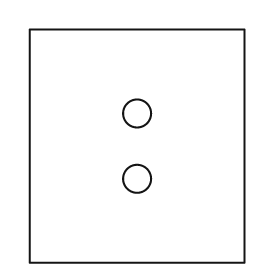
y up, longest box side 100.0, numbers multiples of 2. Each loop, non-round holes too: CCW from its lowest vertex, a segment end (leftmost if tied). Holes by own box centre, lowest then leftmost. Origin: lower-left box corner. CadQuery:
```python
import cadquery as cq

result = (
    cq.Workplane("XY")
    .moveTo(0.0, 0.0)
    .lineTo(92.0, 0.0)
    .lineTo(92.0, 100.0)
    .lineTo(0.0, 100.0)
    .close()
    .moveTo(46.0, 36.0)
    .circle(6.0)
    .moveTo(46.0, 64.0)
    .circle(6.0)
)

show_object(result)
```